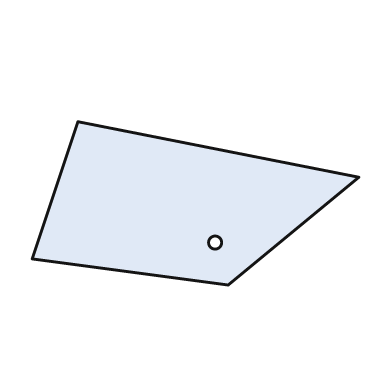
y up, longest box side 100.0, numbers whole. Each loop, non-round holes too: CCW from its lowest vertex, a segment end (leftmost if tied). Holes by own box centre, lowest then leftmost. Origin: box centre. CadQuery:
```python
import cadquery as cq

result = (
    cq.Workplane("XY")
    .moveTo(10.0, -25.0)
    .lineTo(50.0, 8.0)
    .lineTo(-36.0, 25.0)
    .lineTo(-50.0, -17.0)
    .close()
    .moveTo(6.0, -12.0)
    .circle(2.0)
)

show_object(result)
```